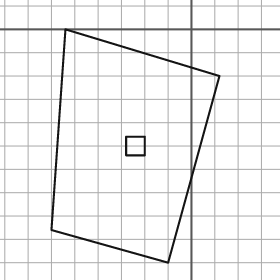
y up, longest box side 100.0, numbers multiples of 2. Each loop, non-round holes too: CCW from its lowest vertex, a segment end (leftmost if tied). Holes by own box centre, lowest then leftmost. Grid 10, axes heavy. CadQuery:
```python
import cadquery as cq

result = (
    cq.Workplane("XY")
    .moveTo(-10.0, -100.0)
    .lineTo(12.0, -20.0)
    .lineTo(-54.0, 0.0)
    .lineTo(-60.0, -86.0)
    .close()
    .moveTo(-28.0, -54.0)
    .lineTo(-20.0, -54.0)
    .lineTo(-20.0, -46.0)
    .lineTo(-28.0, -46.0)
    .close()
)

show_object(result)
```